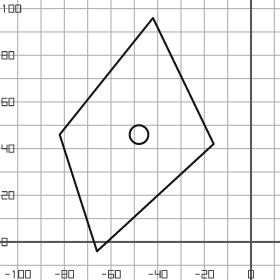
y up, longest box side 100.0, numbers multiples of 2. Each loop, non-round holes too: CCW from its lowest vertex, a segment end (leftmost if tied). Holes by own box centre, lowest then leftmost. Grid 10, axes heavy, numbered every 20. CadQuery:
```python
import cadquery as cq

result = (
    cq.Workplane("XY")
    .moveTo(-66.0, -4.0)
    .lineTo(-16.0, 42.0)
    .lineTo(-42.0, 96.0)
    .lineTo(-82.0, 46.0)
    .close()
    .moveTo(-48.0, 46.0)
    .circle(4.0)
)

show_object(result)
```